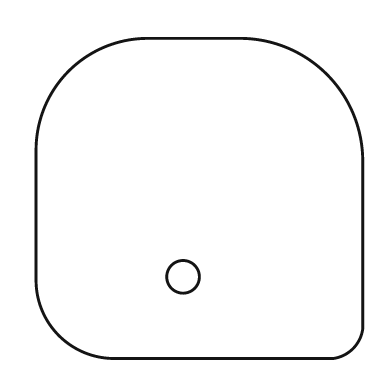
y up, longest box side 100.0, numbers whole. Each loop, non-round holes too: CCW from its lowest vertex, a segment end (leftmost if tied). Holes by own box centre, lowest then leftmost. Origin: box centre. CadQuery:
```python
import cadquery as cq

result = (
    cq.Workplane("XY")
    .moveTo(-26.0, -49.0)
    .lineTo(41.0, -49.0)
    .threePointArc((47.0, -46.0), (50.0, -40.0))
    .lineTo(50.0, 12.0)
    .threePointArc((39.0, 38.0), (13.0, 49.0))
    .lineTo(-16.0, 49.0)
    .threePointArc((-40.0, 39.0), (-50.0, 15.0))
    .lineTo(-50.0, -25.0)
    .threePointArc((-43.0, -42.0), (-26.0, -49.0))
    .close()
    .moveTo(-5.0, -24.0)
    .circle(5.0)
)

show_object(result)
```